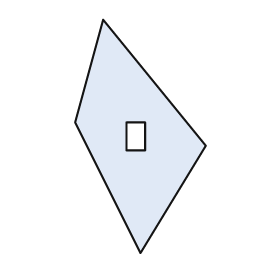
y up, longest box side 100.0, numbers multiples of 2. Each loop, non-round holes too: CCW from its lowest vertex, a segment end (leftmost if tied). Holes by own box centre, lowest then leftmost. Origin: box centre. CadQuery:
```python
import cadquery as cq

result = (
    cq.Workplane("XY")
    .moveTo(0.0, -50.0)
    .lineTo(28.0, -4.0)
    .lineTo(-16.0, 50.0)
    .lineTo(-28.0, 6.0)
    .close()
    .moveTo(-6.0, -6.0)
    .lineTo(2.0, -6.0)
    .lineTo(2.0, 6.0)
    .lineTo(-6.0, 6.0)
    .close()
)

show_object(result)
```